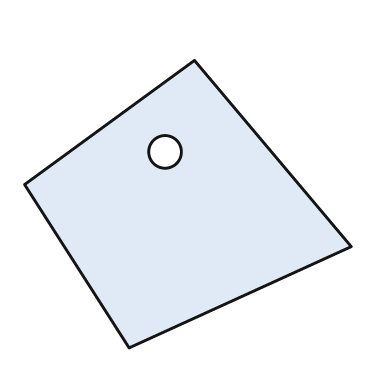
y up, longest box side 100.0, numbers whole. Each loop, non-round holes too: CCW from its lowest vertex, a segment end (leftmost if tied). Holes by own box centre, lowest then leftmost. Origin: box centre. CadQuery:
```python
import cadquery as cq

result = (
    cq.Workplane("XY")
    .moveTo(-18.0, -44.0)
    .lineTo(50.0, -13.0)
    .lineTo(2.0, 44.0)
    .lineTo(-50.0, 6.0)
    .close()
    .moveTo(-7.0, 16.0)
    .circle(5.0)
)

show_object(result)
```